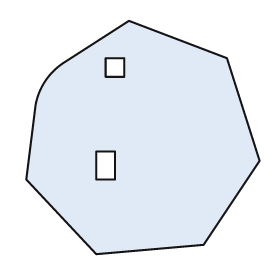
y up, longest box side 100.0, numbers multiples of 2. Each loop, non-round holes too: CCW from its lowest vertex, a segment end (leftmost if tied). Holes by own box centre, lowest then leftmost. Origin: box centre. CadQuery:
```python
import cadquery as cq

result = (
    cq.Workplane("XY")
    .moveTo(-20.0, -50.0)
    .lineTo(26.0, -46.0)
    .lineTo(50.0, -10.0)
    .lineTo(36.0, 34.0)
    .lineTo(-6.0, 50.0)
    .lineTo(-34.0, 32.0)
    .threePointArc((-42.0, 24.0), (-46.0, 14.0))
    .lineTo(-50.0, -18.0)
    .close()
    .moveTo(-20.0, -18.0)
    .lineTo(-12.0, -18.0)
    .lineTo(-12.0, -6.0)
    .lineTo(-20.0, -6.0)
    .close()
    .moveTo(-16.0, 26.0)
    .lineTo(-8.0, 26.0)
    .lineTo(-8.0, 34.0)
    .lineTo(-16.0, 34.0)
    .close()
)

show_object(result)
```